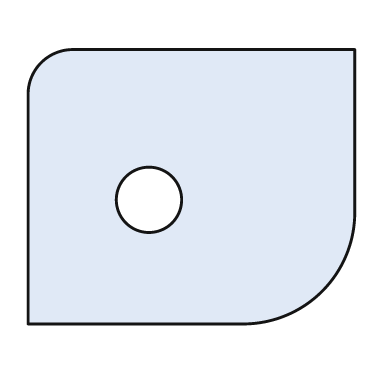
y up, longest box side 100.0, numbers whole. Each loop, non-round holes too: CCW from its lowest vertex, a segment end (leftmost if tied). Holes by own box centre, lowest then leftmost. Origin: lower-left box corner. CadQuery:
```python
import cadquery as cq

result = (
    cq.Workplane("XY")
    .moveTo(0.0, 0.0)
    .lineTo(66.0, 0.0)
    .threePointArc((90.0, 10.0), (100.0, 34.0))
    .lineTo(100.0, 84.0)
    .lineTo(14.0, 84.0)
    .threePointArc((4.0, 80.0), (0.0, 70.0))
    .close()
    .moveTo(37.0, 38.0)
    .circle(10.0)
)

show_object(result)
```